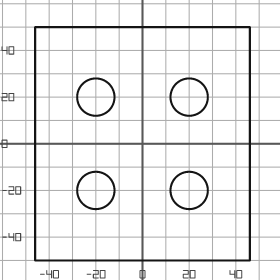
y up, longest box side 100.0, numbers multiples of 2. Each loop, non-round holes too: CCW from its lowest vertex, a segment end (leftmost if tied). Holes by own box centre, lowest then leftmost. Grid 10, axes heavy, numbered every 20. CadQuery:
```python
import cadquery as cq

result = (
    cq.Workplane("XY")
    .moveTo(-46.0, -50.0)
    .lineTo(46.0, -50.0)
    .lineTo(46.0, 50.0)
    .lineTo(-46.0, 50.0)
    .close()
    .moveTo(-20.0, -20.0)
    .circle(8.0)
    .moveTo(20.0, -20.0)
    .circle(8.0)
    .moveTo(-20.0, 20.0)
    .circle(8.0)
    .moveTo(20.0, 20.0)
    .circle(8.0)
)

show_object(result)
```